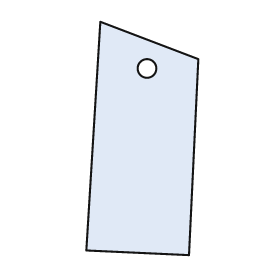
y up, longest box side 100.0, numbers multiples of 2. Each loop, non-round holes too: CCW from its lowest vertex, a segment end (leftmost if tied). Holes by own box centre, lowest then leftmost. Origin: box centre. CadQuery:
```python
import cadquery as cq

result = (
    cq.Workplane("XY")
    .moveTo(20.0, -50.0)
    .lineTo(24.0, 34.0)
    .lineTo(-18.0, 50.0)
    .lineTo(-24.0, -48.0)
    .close()
    .moveTo(2.0, 30.0)
    .circle(4.0)
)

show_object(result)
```